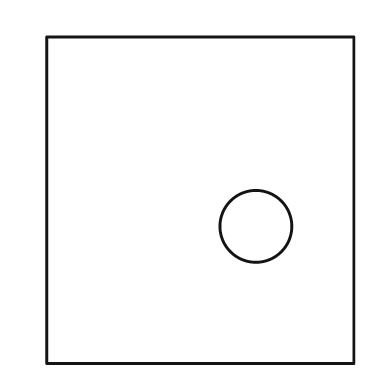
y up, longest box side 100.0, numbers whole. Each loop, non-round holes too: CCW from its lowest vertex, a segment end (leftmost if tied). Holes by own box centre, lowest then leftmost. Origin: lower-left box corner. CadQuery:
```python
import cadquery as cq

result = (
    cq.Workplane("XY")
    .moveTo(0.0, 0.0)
    .lineTo(94.0, 0.0)
    .lineTo(94.0, 100.0)
    .lineTo(0.0, 100.0)
    .close()
    .moveTo(64.0, 42.0)
    .circle(11.0)
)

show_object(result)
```